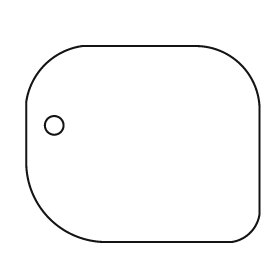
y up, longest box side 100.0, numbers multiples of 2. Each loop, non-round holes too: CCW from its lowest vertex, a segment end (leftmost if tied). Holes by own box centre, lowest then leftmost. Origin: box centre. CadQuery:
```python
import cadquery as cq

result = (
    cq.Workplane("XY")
    .moveTo(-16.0, -42.0)
    .lineTo(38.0, -42.0)
    .threePointArc((46.0, -38.0), (50.0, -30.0))
    .lineTo(50.0, 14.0)
    .threePointArc((42.0, 34.0), (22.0, 42.0))
    .lineTo(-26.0, 42.0)
    .threePointArc((-42.0, 34.0), (-50.0, 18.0))
    .lineTo(-50.0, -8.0)
    .threePointArc((-40.0, -32.0), (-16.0, -42.0))
    .close()
    .moveTo(-38.0, 8.0)
    .circle(4.0)
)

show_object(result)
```